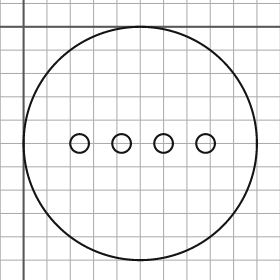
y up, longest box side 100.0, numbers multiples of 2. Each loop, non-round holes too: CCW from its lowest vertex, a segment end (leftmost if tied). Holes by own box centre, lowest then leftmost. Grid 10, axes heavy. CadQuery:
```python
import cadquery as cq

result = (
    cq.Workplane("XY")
    .moveTo(50.0, -50.0)
    .circle(50.0)
    .moveTo(24.0, -50.0)
    .circle(4.0)
    .moveTo(42.0, -50.0)
    .circle(4.0)
    .moveTo(60.0, -50.0)
    .circle(4.0)
    .moveTo(78.0, -50.0)
    .circle(4.0)
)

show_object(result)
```